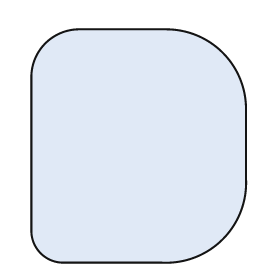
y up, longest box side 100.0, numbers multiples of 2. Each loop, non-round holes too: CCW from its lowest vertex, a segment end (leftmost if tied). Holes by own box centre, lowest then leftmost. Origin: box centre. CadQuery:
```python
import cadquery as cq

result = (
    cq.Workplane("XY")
    .moveTo(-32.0, -50.0)
    .lineTo(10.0, -50.0)
    .threePointArc((36.0, -40.0), (46.0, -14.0))
    .lineTo(46.0, 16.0)
    .threePointArc((36.0, 40.0), (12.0, 50.0))
    .lineTo(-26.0, 50.0)
    .threePointArc((-40.0, 44.0), (-46.0, 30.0))
    .lineTo(-46.0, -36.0)
    .threePointArc((-42.0, -46.0), (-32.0, -50.0))
    .close()
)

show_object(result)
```